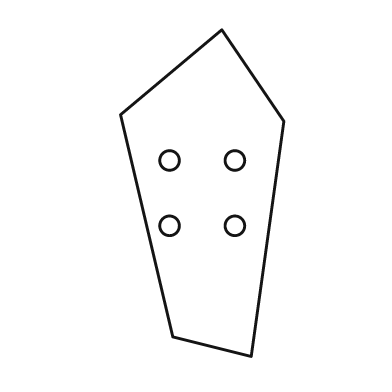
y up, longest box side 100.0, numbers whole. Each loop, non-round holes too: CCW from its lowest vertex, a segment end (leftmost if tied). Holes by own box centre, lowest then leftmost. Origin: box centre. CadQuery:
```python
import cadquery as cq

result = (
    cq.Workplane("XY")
    .moveTo(15.0, -50.0)
    .lineTo(25.0, 22.0)
    .lineTo(6.0, 50.0)
    .lineTo(-25.0, 24.0)
    .lineTo(-9.0, -44.0)
    .close()
    .moveTo(-10.0, -10.0)
    .circle(3.0)
    .moveTo(10.0, -10.0)
    .circle(3.0)
    .moveTo(-10.0, 10.0)
    .circle(3.0)
    .moveTo(10.0, 10.0)
    .circle(3.0)
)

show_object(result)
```